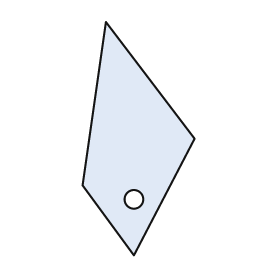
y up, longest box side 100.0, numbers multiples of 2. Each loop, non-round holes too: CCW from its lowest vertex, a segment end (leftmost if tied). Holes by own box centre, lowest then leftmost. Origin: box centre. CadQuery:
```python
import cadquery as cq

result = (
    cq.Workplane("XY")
    .moveTo(-2.0, -50.0)
    .lineTo(24.0, 0.0)
    .lineTo(-14.0, 50.0)
    .lineTo(-24.0, -20.0)
    .close()
    .moveTo(-2.0, -26.0)
    .circle(4.0)
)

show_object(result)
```